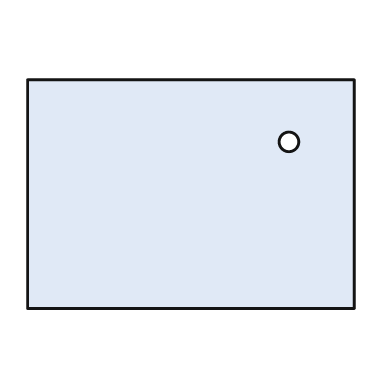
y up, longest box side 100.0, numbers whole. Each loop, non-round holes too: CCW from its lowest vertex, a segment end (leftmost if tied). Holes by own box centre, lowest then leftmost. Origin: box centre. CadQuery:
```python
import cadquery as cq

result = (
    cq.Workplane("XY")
    .moveTo(-50.0, -35.0)
    .lineTo(50.0, -35.0)
    .lineTo(50.0, 35.0)
    .lineTo(-50.0, 35.0)
    .close()
    .moveTo(30.0, 16.0)
    .circle(3.0)
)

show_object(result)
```